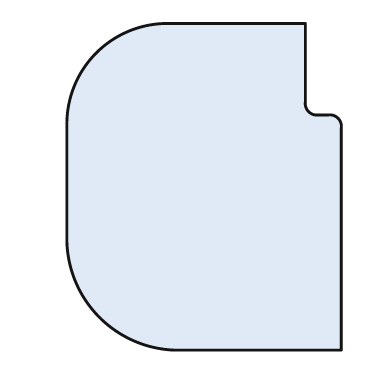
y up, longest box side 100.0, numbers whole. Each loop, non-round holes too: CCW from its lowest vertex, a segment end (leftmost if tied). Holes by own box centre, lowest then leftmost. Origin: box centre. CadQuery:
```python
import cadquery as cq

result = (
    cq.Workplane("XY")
    .moveTo(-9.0, -50.0)
    .lineTo(42.0, -50.0)
    .lineTo(42.0, 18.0)
    .threePointArc((41.0, 21.0), (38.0, 22.0))
    .lineTo(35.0, 22.0)
    .threePointArc((32.0, 23.0), (31.0, 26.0))
    .lineTo(31.0, 50.0)
    .lineTo(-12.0, 50.0)
    .threePointArc((-33.0, 41.0), (-42.0, 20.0))
    .lineTo(-42.0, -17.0)
    .threePointArc((-32.0, -40.0), (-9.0, -50.0))
    .close()
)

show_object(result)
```